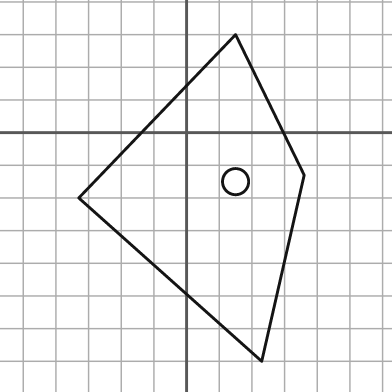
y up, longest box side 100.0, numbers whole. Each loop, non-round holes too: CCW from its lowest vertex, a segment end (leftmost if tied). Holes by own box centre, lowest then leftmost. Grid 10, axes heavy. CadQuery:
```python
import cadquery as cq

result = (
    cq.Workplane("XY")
    .moveTo(23.0, -70.0)
    .lineTo(36.0, -13.0)
    .lineTo(15.0, 30.0)
    .lineTo(-33.0, -20.0)
    .close()
    .moveTo(15.0, -15.0)
    .circle(4.0)
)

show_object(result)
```